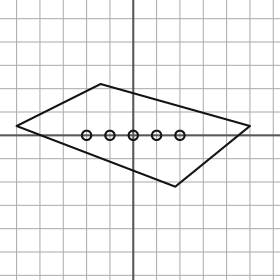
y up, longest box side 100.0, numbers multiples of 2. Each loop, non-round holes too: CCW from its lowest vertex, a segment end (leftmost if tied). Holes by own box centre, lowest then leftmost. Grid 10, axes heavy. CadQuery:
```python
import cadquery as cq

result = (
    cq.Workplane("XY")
    .moveTo(18.0, -22.0)
    .lineTo(50.0, 4.0)
    .lineTo(-14.0, 22.0)
    .lineTo(-50.0, 4.0)
    .close()
    .moveTo(-20.0, 0.0)
    .circle(2.0)
    .moveTo(-10.0, 0.0)
    .circle(2.0)
    .moveTo(0.0, 0.0)
    .circle(2.0)
    .moveTo(10.0, 0.0)
    .circle(2.0)
    .moveTo(20.0, 0.0)
    .circle(2.0)
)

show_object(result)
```